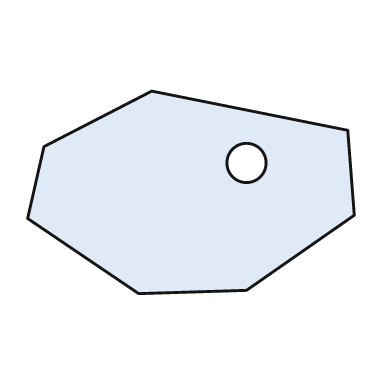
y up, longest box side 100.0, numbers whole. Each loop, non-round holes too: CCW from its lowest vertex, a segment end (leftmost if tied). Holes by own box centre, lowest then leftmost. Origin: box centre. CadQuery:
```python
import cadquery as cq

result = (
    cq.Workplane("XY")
    .moveTo(-16.0, -31.0)
    .lineTo(17.0, -30.0)
    .lineTo(50.0, -7.0)
    .lineTo(48.0, 19.0)
    .lineTo(-12.0, 31.0)
    .lineTo(-45.0, 14.0)
    .lineTo(-50.0, -8.0)
    .close()
    .moveTo(17.0, 9.0)
    .circle(6.0)
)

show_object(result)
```